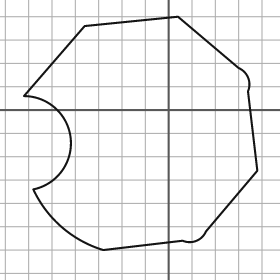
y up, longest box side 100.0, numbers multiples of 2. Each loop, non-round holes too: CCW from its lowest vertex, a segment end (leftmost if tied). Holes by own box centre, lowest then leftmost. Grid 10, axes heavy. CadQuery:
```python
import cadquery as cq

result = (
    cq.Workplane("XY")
    .moveTo(-28.0, -60.0)
    .lineTo(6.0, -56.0)
    .threePointArc((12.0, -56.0), (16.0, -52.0))
    .lineTo(38.0, -26.0)
    .lineTo(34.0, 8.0)
    .threePointArc((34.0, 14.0), (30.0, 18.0))
    .lineTo(4.0, 40.0)
    .lineTo(-36.0, 36.0)
    .lineTo(-62.0, 6.0)
    .threePointArc((-42.0, -12.0), (-58.0, -34.0))
    .threePointArc((-46.0, -50.0), (-28.0, -60.0))
    .close()
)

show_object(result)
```